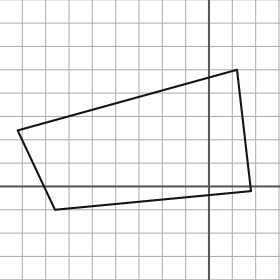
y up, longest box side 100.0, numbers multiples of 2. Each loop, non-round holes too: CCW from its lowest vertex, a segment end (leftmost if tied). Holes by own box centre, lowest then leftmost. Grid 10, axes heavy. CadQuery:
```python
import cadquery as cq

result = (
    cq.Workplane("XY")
    .moveTo(-66.0, -10.0)
    .lineTo(18.0, -2.0)
    .lineTo(12.0, 50.0)
    .lineTo(-82.0, 24.0)
    .close()
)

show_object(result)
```